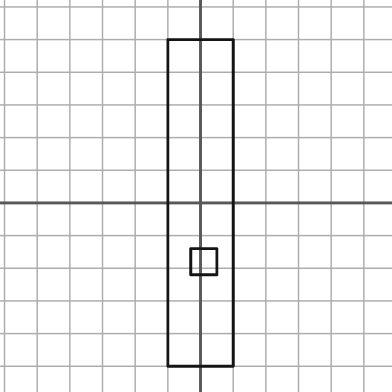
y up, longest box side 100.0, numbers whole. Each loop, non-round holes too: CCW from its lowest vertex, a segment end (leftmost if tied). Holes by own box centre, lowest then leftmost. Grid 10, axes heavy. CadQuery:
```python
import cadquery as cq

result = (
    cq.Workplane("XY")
    .moveTo(-10.0, -50.0)
    .lineTo(10.0, -50.0)
    .lineTo(10.0, 50.0)
    .lineTo(-10.0, 50.0)
    .close()
    .moveTo(-3.0, -22.0)
    .lineTo(5.0, -22.0)
    .lineTo(5.0, -14.0)
    .lineTo(-3.0, -14.0)
    .close()
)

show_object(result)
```